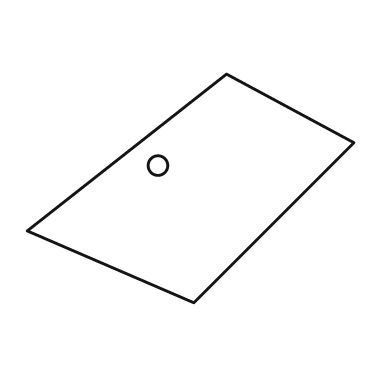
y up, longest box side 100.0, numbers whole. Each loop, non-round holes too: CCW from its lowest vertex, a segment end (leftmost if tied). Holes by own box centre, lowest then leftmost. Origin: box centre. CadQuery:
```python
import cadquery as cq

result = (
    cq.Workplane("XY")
    .moveTo(1.0, -35.0)
    .lineTo(50.0, 14.0)
    .lineTo(11.0, 35.0)
    .lineTo(-50.0, -13.0)
    .close()
    .moveTo(-10.0, 7.0)
    .circle(3.0)
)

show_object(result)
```